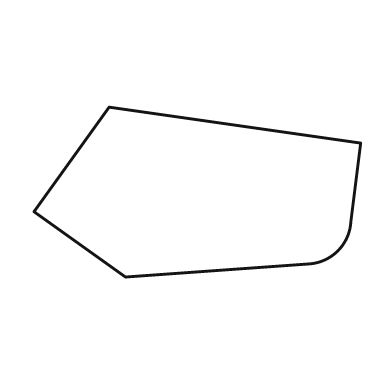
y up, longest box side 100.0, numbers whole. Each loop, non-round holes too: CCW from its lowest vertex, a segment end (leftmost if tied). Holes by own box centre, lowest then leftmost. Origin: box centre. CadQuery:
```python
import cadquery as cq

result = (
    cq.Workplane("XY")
    .moveTo(-22.0, -26.0)
    .lineTo(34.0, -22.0)
    .threePointArc((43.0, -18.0), (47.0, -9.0))
    .lineTo(50.0, 15.0)
    .lineTo(-27.0, 26.0)
    .lineTo(-50.0, -6.0)
    .close()
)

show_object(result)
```